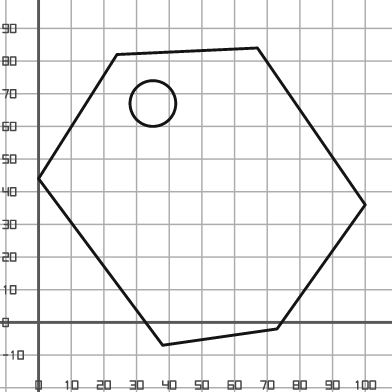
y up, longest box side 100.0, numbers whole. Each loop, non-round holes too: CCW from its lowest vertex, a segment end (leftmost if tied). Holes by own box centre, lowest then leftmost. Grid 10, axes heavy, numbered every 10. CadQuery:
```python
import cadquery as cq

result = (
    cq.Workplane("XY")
    .moveTo(38.0, -7.0)
    .lineTo(73.0, -2.0)
    .lineTo(100.0, 36.0)
    .lineTo(67.0, 84.0)
    .lineTo(24.0, 82.0)
    .lineTo(0.0, 44.0)
    .close()
    .moveTo(35.0, 67.0)
    .circle(7.0)
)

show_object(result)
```